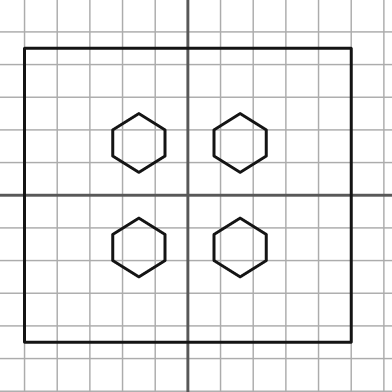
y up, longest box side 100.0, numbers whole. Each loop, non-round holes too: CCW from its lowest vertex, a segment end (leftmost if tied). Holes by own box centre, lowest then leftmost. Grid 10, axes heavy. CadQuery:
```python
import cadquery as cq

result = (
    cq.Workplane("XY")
    .moveTo(-50.0, -45.0)
    .lineTo(50.0, -45.0)
    .lineTo(50.0, 45.0)
    .lineTo(-50.0, 45.0)
    .close()
    .moveTo(-15.0, -25.0)
    .lineTo(-7.0, -20.0)
    .lineTo(-7.0, -12.0)
    .lineTo(-15.0, -7.0)
    .lineTo(-23.0, -12.0)
    .lineTo(-23.0, -20.0)
    .close()
    .moveTo(16.0, -25.0)
    .lineTo(24.0, -20.0)
    .lineTo(24.0, -12.0)
    .lineTo(16.0, -7.0)
    .lineTo(8.0, -12.0)
    .lineTo(8.0, -20.0)
    .close()
    .moveTo(-15.0, 7.0)
    .lineTo(-7.0, 12.0)
    .lineTo(-7.0, 20.0)
    .lineTo(-15.0, 25.0)
    .lineTo(-23.0, 20.0)
    .lineTo(-23.0, 12.0)
    .close()
    .moveTo(16.0, 7.0)
    .lineTo(24.0, 12.0)
    .lineTo(24.0, 20.0)
    .lineTo(16.0, 25.0)
    .lineTo(8.0, 20.0)
    .lineTo(8.0, 12.0)
    .close()
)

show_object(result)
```